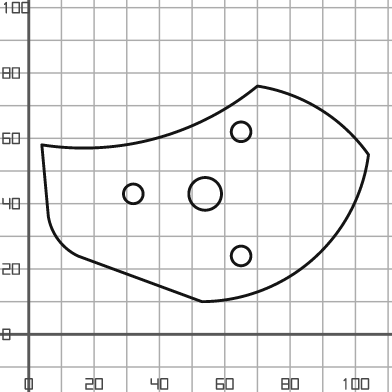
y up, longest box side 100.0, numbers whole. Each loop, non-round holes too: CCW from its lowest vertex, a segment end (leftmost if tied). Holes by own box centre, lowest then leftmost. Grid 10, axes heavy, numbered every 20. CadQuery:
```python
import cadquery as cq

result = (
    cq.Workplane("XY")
    .moveTo(53.0, 10.0)
    .threePointArc((87.0, 23.0), (104.0, 55.0))
    .threePointArc((89.0, 69.0), (70.0, 76.0))
    .threePointArc((39.0, 60.0), (4.0, 58.0))
    .lineTo(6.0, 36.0)
    .threePointArc((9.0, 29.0), (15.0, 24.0))
    .close()
    .moveTo(65.0, 24.0)
    .circle(3.0)
    .moveTo(32.0, 43.0)
    .circle(3.0)
    .moveTo(54.0, 43.0)
    .circle(5.0)
    .moveTo(65.0, 62.0)
    .circle(3.0)
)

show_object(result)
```